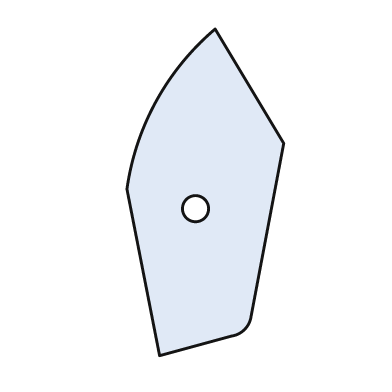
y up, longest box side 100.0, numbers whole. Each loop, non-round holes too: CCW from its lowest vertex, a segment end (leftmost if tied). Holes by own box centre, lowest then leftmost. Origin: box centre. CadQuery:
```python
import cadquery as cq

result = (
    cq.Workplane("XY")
    .moveTo(-14.0, -50.0)
    .lineTo(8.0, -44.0)
    .threePointArc((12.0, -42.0), (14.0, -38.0))
    .lineTo(24.0, 15.0)
    .lineTo(3.0, 50.0)
    .threePointArc((-15.0, 28.0), (-24.0, 1.0))
    .close()
    .moveTo(-3.0, -5.0)
    .circle(4.0)
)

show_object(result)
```